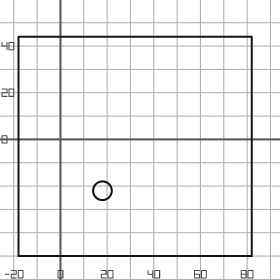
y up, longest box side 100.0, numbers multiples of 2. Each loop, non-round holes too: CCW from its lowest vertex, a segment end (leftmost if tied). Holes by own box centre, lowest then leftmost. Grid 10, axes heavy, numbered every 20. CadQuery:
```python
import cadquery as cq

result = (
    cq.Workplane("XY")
    .moveTo(-18.0, -50.0)
    .lineTo(82.0, -50.0)
    .lineTo(82.0, 44.0)
    .lineTo(-18.0, 44.0)
    .close()
    .moveTo(18.0, -22.0)
    .circle(4.0)
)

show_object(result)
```